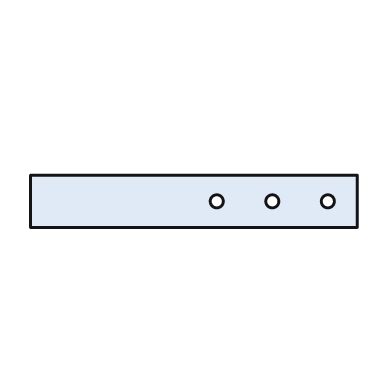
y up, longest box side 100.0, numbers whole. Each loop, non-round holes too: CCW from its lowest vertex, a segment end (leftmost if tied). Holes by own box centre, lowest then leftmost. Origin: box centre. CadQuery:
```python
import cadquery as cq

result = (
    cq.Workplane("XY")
    .moveTo(-50.0, -8.0)
    .lineTo(50.0, -8.0)
    .lineTo(50.0, 8.0)
    .lineTo(-50.0, 8.0)
    .close()
    .moveTo(7.0, 0.0)
    .circle(2.0)
    .moveTo(24.0, 0.0)
    .circle(2.0)
    .moveTo(41.0, 0.0)
    .circle(2.0)
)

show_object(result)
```